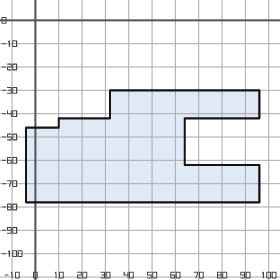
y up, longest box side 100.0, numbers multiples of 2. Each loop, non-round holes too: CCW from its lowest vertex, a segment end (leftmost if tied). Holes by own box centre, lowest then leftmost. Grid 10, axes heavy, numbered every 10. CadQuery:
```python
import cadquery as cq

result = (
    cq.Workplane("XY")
    .moveTo(-4.0, -78.0)
    .lineTo(96.0, -78.0)
    .lineTo(96.0, -62.0)
    .lineTo(64.0, -62.0)
    .lineTo(64.0, -42.0)
    .lineTo(96.0, -42.0)
    .lineTo(96.0, -30.0)
    .lineTo(32.0, -30.0)
    .lineTo(32.0, -42.0)
    .lineTo(10.0, -42.0)
    .lineTo(10.0, -46.0)
    .lineTo(-4.0, -46.0)
    .close()
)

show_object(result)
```